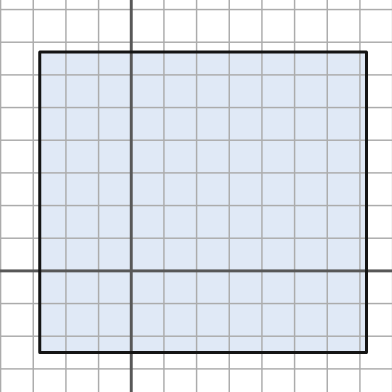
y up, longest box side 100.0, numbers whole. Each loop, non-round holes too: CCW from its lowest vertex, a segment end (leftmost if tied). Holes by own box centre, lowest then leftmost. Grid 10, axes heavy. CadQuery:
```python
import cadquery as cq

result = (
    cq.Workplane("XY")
    .moveTo(-28.0, -25.0)
    .lineTo(72.0, -25.0)
    .lineTo(72.0, 67.0)
    .lineTo(-28.0, 67.0)
    .close()
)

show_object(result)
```